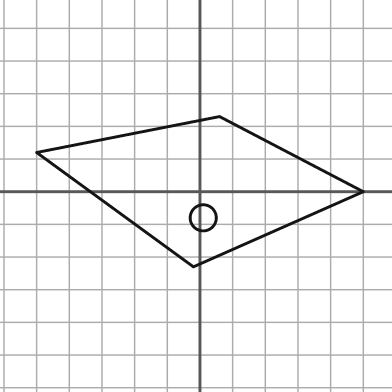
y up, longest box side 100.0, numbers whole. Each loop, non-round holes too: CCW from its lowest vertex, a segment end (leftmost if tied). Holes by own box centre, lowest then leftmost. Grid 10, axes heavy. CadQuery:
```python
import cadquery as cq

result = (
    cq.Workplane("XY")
    .moveTo(-2.0, -23.0)
    .lineTo(50.0, 0.0)
    .lineTo(6.0, 23.0)
    .lineTo(-50.0, 12.0)
    .close()
    .moveTo(1.0, -8.0)
    .circle(4.0)
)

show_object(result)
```